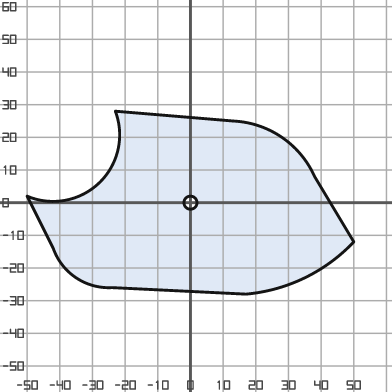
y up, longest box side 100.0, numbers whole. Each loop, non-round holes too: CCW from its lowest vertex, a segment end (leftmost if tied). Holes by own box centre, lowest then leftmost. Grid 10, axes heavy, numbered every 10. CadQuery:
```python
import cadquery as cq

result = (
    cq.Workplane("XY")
    .moveTo(17.0, -28.0)
    .threePointArc((35.0, -23.0), (50.0, -12.0))
    .lineTo(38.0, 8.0)
    .threePointArc((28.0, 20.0), (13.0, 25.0))
    .lineTo(-23.0, 28.0)
    .threePointArc((-28.0, 6.0), (-50.0, 2.0))
    .lineTo(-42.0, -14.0)
    .threePointArc((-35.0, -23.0), (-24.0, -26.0))
    .close()
    .moveTo(0.0, 0.0)
    .circle(2.0)
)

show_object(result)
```